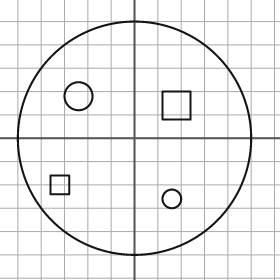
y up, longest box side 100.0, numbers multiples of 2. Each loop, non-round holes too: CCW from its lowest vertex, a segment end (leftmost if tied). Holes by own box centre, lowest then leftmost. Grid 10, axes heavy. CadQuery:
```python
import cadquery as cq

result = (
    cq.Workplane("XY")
    .moveTo(0.0, 0.0)
    .circle(50.0)
    .moveTo(16.0, -26.0)
    .circle(4.0)
    .moveTo(-36.0, -24.0)
    .lineTo(-28.0, -24.0)
    .lineTo(-28.0, -16.0)
    .lineTo(-36.0, -16.0)
    .close()
    .moveTo(12.0, 8.0)
    .lineTo(24.0, 8.0)
    .lineTo(24.0, 20.0)
    .lineTo(12.0, 20.0)
    .close()
    .moveTo(-24.0, 18.0)
    .circle(6.0)
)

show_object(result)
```